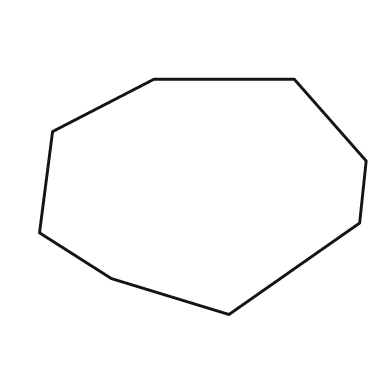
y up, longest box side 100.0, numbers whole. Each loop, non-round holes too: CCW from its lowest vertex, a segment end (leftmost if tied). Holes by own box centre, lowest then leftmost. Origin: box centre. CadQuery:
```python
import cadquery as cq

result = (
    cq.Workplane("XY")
    .moveTo(8.0, -36.0)
    .lineTo(48.0, -8.0)
    .lineTo(50.0, 11.0)
    .lineTo(28.0, 36.0)
    .lineTo(-15.0, 36.0)
    .lineTo(-46.0, 20.0)
    .lineTo(-50.0, -11.0)
    .lineTo(-28.0, -25.0)
    .close()
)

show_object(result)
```